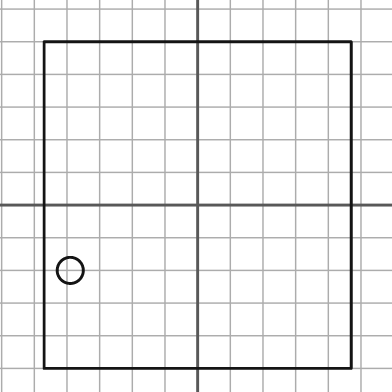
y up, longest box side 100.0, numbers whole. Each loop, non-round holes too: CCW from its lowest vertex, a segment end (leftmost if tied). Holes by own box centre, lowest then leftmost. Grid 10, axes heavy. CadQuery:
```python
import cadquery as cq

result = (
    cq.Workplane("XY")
    .moveTo(-47.0, -50.0)
    .lineTo(47.0, -50.0)
    .lineTo(47.0, 50.0)
    .lineTo(-47.0, 50.0)
    .close()
    .moveTo(-39.0, -20.0)
    .circle(4.0)
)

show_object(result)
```